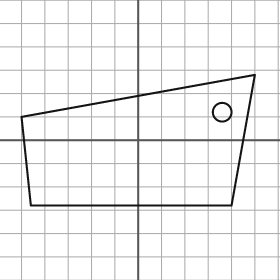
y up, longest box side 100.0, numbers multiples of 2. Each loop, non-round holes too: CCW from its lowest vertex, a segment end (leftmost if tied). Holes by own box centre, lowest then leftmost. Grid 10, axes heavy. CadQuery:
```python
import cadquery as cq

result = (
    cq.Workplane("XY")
    .moveTo(-46.0, -28.0)
    .lineTo(40.0, -28.0)
    .lineTo(50.0, 28.0)
    .lineTo(-50.0, 10.0)
    .close()
    .moveTo(36.0, 12.0)
    .circle(4.0)
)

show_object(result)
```